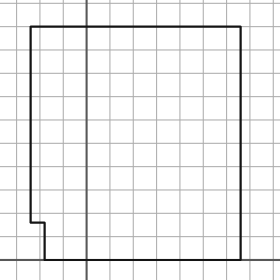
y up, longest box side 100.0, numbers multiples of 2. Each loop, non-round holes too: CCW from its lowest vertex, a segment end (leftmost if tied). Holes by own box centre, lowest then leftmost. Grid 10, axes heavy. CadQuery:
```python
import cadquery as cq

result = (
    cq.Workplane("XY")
    .moveTo(-18.0, 0.0)
    .lineTo(66.0, 0.0)
    .lineTo(66.0, 100.0)
    .lineTo(-24.0, 100.0)
    .lineTo(-24.0, 16.0)
    .lineTo(-18.0, 16.0)
    .close()
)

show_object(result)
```